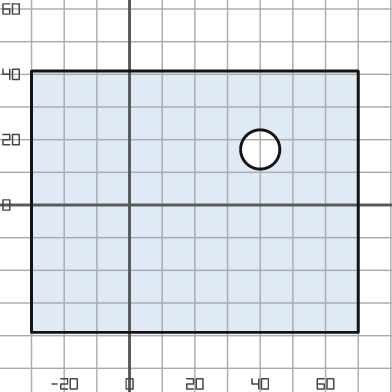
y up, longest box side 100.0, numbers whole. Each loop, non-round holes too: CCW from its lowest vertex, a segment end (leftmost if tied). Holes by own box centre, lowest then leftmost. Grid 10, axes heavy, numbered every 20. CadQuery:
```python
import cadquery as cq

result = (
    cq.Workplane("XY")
    .moveTo(-30.0, -39.0)
    .lineTo(70.0, -39.0)
    .lineTo(70.0, 41.0)
    .lineTo(-30.0, 41.0)
    .close()
    .moveTo(40.0, 17.0)
    .circle(6.0)
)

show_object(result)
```